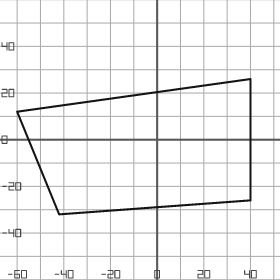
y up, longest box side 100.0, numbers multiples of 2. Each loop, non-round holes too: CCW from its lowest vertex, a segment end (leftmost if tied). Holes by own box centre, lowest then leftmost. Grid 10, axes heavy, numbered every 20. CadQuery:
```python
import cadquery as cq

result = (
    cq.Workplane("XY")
    .moveTo(-42.0, -32.0)
    .lineTo(40.0, -26.0)
    .lineTo(40.0, 26.0)
    .lineTo(-60.0, 12.0)
    .close()
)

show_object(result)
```